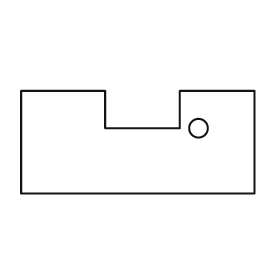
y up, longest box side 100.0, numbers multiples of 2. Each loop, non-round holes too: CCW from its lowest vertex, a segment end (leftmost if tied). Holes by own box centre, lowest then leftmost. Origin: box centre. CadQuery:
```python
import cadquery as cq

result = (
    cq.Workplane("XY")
    .moveTo(-50.0, -22.0)
    .lineTo(50.0, -22.0)
    .lineTo(50.0, 22.0)
    .lineTo(18.0, 22.0)
    .lineTo(18.0, 6.0)
    .lineTo(-14.0, 6.0)
    .lineTo(-14.0, 22.0)
    .lineTo(-50.0, 22.0)
    .close()
    .moveTo(26.0, 6.0)
    .circle(4.0)
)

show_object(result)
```